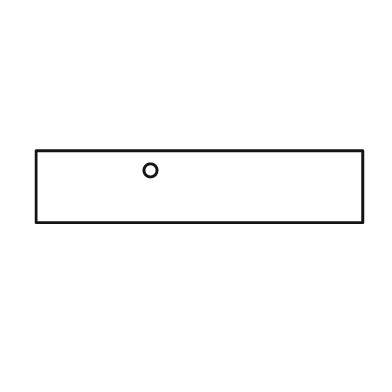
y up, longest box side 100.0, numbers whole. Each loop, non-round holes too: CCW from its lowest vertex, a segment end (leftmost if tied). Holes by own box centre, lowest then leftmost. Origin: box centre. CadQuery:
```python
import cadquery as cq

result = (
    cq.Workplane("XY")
    .moveTo(-50.0, -11.0)
    .lineTo(50.0, -11.0)
    .lineTo(50.0, 11.0)
    .lineTo(-50.0, 11.0)
    .close()
    .moveTo(-15.0, 5.0)
    .circle(2.0)
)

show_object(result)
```